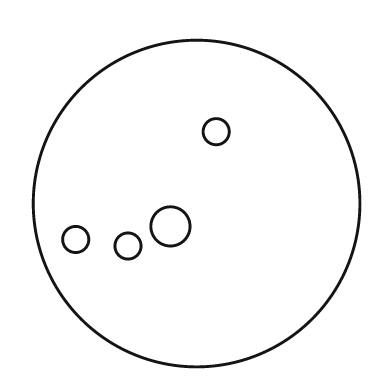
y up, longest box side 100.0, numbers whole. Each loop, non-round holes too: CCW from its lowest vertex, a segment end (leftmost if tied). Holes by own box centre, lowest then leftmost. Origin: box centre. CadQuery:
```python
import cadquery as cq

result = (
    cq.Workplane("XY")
    .moveTo(0.0, 0.0)
    .circle(50.0)
    .moveTo(-21.0, -13.0)
    .circle(4.0)
    .moveTo(-37.0, -11.0)
    .circle(4.0)
    .moveTo(-8.0, -7.0)
    .circle(6.0)
    .moveTo(6.0, 22.0)
    .circle(4.0)
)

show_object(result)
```